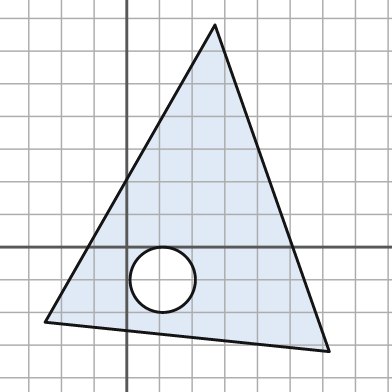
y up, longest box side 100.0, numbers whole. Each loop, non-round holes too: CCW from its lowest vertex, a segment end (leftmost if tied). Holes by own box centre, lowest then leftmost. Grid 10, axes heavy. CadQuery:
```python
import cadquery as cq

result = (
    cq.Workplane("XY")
    .moveTo(62.0, -32.0)
    .lineTo(27.0, 68.0)
    .lineTo(-25.0, -23.0)
    .close()
    .moveTo(11.0, -10.0)
    .circle(10.0)
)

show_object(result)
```